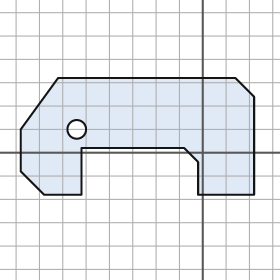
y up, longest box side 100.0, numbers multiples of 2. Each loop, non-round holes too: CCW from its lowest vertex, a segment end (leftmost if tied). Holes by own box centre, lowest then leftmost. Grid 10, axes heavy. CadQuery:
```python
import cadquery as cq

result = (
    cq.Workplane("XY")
    .moveTo(-68.0, -18.0)
    .lineTo(-52.0, -18.0)
    .lineTo(-52.0, 2.0)
    .lineTo(-8.0, 2.0)
    .lineTo(-2.0, -4.0)
    .lineTo(-2.0, -18.0)
    .lineTo(22.0, -18.0)
    .lineTo(22.0, 24.0)
    .lineTo(14.0, 32.0)
    .lineTo(-62.0, 32.0)
    .lineTo(-78.0, 10.0)
    .lineTo(-78.0, -8.0)
    .close()
    .moveTo(-54.0, 10.0)
    .circle(4.0)
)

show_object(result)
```